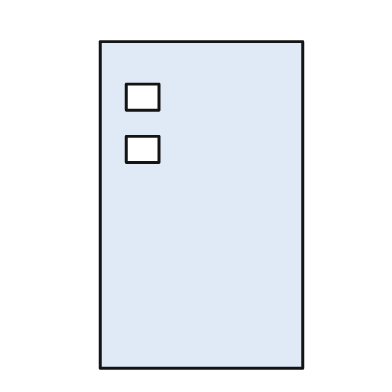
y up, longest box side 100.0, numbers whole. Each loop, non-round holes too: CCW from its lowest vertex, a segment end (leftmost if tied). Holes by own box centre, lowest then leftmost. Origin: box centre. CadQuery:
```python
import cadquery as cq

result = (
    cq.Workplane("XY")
    .moveTo(-31.0, -50.0)
    .lineTo(31.0, -50.0)
    .lineTo(31.0, 50.0)
    .lineTo(-31.0, 50.0)
    .close()
    .moveTo(-23.0, 13.0)
    .lineTo(-13.0, 13.0)
    .lineTo(-13.0, 21.0)
    .lineTo(-23.0, 21.0)
    .close()
    .moveTo(-23.0, 29.0)
    .lineTo(-13.0, 29.0)
    .lineTo(-13.0, 37.0)
    .lineTo(-23.0, 37.0)
    .close()
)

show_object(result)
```